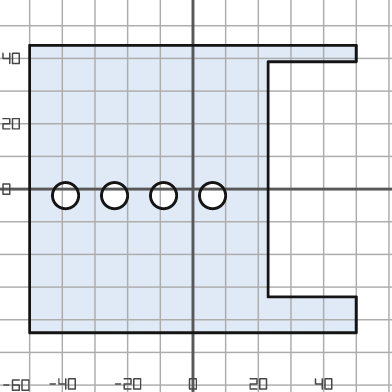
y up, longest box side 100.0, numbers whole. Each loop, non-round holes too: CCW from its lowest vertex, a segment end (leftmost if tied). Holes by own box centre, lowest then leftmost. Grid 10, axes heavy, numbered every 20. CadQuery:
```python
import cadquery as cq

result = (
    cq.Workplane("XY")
    .moveTo(-50.0, -44.0)
    .lineTo(50.0, -44.0)
    .lineTo(50.0, -33.0)
    .lineTo(23.0, -33.0)
    .lineTo(23.0, 39.0)
    .lineTo(50.0, 39.0)
    .lineTo(50.0, 44.0)
    .lineTo(-50.0, 44.0)
    .close()
    .moveTo(-39.0, -2.0)
    .circle(4.0)
    .moveTo(-24.0, -2.0)
    .circle(4.0)
    .moveTo(-9.0, -2.0)
    .circle(4.0)
    .moveTo(6.0, -2.0)
    .circle(4.0)
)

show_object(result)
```